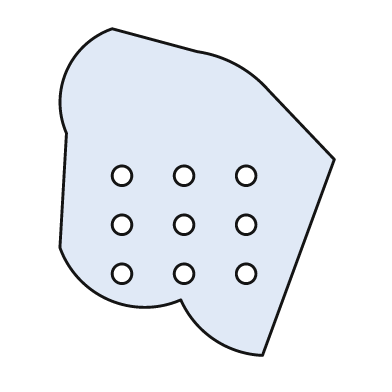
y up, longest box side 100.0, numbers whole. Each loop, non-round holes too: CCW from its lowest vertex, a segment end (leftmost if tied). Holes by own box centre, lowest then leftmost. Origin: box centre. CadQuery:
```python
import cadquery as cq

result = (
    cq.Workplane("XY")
    .moveTo(20.0, -50.0)
    .lineTo(42.0, 10.0)
    .lineTo(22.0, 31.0)
    .threePointArc((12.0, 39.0), (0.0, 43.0))
    .lineTo(-26.0, 50.0)
    .threePointArc((-40.0, 37.0), (-40.0, 18.0))
    .lineTo(-42.0, -17.0)
    .threePointArc((-27.0, -33.0), (-5.0, -33.0))
    .threePointArc((5.0, -45.0), (20.0, -50.0))
    .close()
    .moveTo(-23.0, -25.0)
    .circle(3.0)
    .moveTo(-4.0, -25.0)
    .circle(3.0)
    .moveTo(15.0, -25.0)
    .circle(3.0)
    .moveTo(-23.0, -10.0)
    .circle(3.0)
    .moveTo(-4.0, -10.0)
    .circle(3.0)
    .moveTo(15.0, -10.0)
    .circle(3.0)
    .moveTo(-23.0, 5.0)
    .circle(3.0)
    .moveTo(-4.0, 5.0)
    .circle(3.0)
    .moveTo(15.0, 5.0)
    .circle(3.0)
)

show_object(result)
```